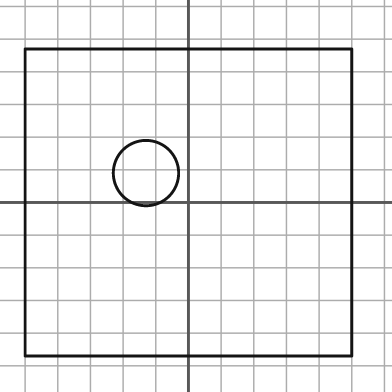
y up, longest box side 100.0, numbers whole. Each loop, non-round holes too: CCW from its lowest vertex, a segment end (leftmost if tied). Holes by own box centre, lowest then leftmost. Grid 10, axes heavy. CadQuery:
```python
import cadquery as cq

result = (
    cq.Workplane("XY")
    .moveTo(-50.0, -47.0)
    .lineTo(50.0, -47.0)
    .lineTo(50.0, 47.0)
    .lineTo(-50.0, 47.0)
    .close()
    .moveTo(-13.0, 9.0)
    .circle(10.0)
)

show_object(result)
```